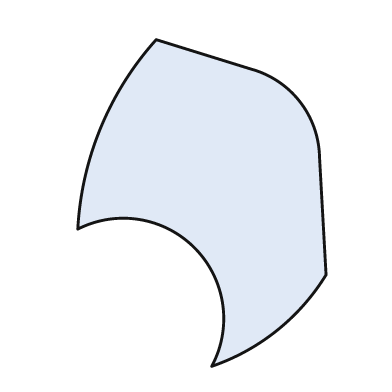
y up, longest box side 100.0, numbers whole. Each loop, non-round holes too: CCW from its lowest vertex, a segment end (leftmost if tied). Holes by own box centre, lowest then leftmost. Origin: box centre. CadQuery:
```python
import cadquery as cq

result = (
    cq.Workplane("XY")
    .moveTo(3.0, -50.0)
    .threePointArc((23.0, -39.0), (38.0, -22.0))
    .lineTo(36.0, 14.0)
    .threePointArc((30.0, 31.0), (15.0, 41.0))
    .lineTo(-14.0, 50.0)
    .threePointArc((-31.0, 23.0), (-38.0, -8.0))
    .threePointArc((-2.0, -14.0), (3.0, -50.0))
    .close()
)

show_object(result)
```